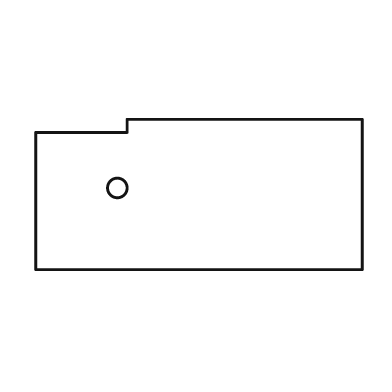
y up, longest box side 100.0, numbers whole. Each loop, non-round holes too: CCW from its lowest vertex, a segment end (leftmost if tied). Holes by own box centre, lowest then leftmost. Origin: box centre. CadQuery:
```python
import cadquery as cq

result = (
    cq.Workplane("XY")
    .moveTo(-50.0, -23.0)
    .lineTo(50.0, -23.0)
    .lineTo(50.0, 23.0)
    .lineTo(-22.0, 23.0)
    .lineTo(-22.0, 19.0)
    .lineTo(-50.0, 19.0)
    .close()
    .moveTo(-25.0, 2.0)
    .circle(3.0)
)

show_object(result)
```